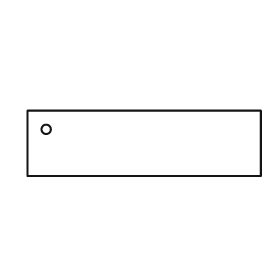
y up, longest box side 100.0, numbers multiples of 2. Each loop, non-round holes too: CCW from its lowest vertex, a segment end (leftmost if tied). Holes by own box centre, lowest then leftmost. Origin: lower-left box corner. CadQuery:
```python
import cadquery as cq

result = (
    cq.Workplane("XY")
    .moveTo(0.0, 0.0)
    .lineTo(100.0, 0.0)
    .lineTo(100.0, 28.0)
    .lineTo(0.0, 28.0)
    .close()
    .moveTo(8.0, 20.0)
    .circle(2.0)
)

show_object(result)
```